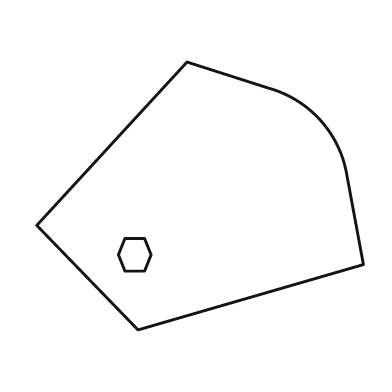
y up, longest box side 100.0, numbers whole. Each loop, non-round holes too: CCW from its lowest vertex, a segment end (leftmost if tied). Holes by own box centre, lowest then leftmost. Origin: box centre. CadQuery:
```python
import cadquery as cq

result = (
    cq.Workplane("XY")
    .moveTo(-19.0, -41.0)
    .lineTo(50.0, -21.0)
    .lineTo(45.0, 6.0)
    .threePointArc((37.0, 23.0), (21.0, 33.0))
    .lineTo(-4.0, 41.0)
    .lineTo(-50.0, -9.0)
    .close()
    .moveTo(-23.0, -23.0)
    .lineTo(-17.0, -23.0)
    .lineTo(-15.0, -18.0)
    .lineTo(-17.0, -13.0)
    .lineTo(-23.0, -13.0)
    .lineTo(-25.0, -18.0)
    .close()
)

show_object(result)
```